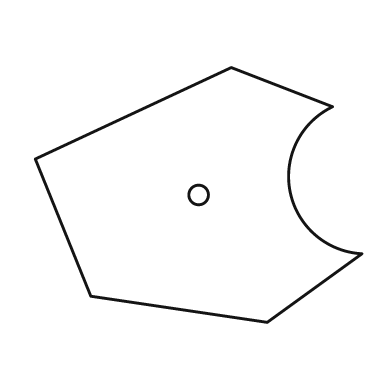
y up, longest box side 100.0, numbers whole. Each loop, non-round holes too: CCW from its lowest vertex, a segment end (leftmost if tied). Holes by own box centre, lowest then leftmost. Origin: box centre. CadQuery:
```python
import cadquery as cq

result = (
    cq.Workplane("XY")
    .moveTo(21.0, -39.0)
    .lineTo(50.0, -18.0)
    .threePointArc((28.0, 1.0), (41.0, 27.0))
    .lineTo(10.0, 39.0)
    .lineTo(-50.0, 11.0)
    .lineTo(-33.0, -31.0)
    .close()
    .moveTo(0.0, 0.0)
    .circle(3.0)
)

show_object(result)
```